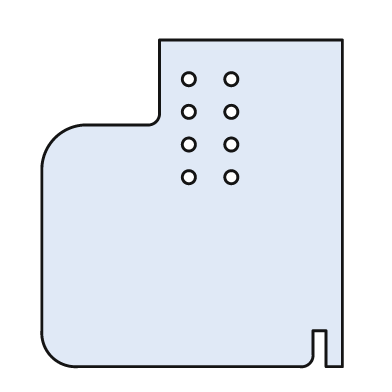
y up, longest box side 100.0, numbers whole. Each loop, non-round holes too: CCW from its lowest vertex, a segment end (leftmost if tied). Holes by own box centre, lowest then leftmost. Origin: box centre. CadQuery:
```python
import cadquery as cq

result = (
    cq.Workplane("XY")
    .moveTo(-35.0, -50.0)
    .lineTo(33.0, -50.0)
    .threePointArc((36.0, -49.0), (37.0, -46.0))
    .lineTo(37.0, -39.0)
    .lineTo(41.0, -39.0)
    .lineTo(41.0, -50.0)
    .lineTo(46.0, -50.0)
    .lineTo(46.0, 50.0)
    .lineTo(-10.0, 50.0)
    .lineTo(-10.0, 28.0)
    .threePointArc((-11.0, 25.0), (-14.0, 24.0))
    .lineTo(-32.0, 24.0)
    .threePointArc((-42.0, 20.0), (-46.0, 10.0))
    .lineTo(-46.0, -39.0)
    .threePointArc((-43.0, -47.0), (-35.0, -50.0))
    .close()
    .moveTo(-1.0, 8.0)
    .circle(2.0)
    .moveTo(12.0, 8.0)
    .circle(2.0)
    .moveTo(-1.0, 18.0)
    .circle(2.0)
    .moveTo(12.0, 18.0)
    .circle(2.0)
    .moveTo(-1.0, 28.0)
    .circle(2.0)
    .moveTo(12.0, 28.0)
    .circle(2.0)
    .moveTo(-1.0, 38.0)
    .circle(2.0)
    .moveTo(12.0, 38.0)
    .circle(2.0)
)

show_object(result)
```